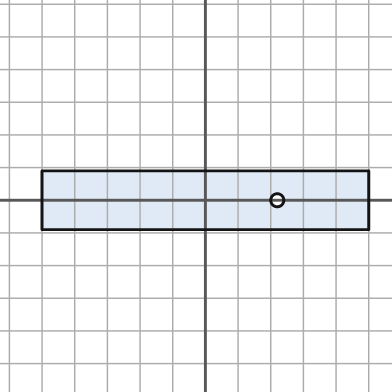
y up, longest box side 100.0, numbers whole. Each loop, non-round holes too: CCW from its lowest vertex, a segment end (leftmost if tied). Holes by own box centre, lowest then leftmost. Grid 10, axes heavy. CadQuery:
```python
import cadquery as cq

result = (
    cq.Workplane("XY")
    .moveTo(-50.0, -9.0)
    .lineTo(50.0, -9.0)
    .lineTo(50.0, 9.0)
    .lineTo(-50.0, 9.0)
    .close()
    .moveTo(22.0, 0.0)
    .circle(2.0)
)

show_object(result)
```